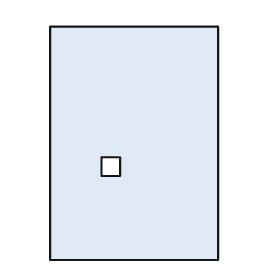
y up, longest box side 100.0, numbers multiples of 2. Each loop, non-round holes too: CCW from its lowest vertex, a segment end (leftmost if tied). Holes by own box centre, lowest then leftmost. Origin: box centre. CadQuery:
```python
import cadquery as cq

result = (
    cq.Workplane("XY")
    .moveTo(-36.0, -50.0)
    .lineTo(36.0, -50.0)
    .lineTo(36.0, 50.0)
    .lineTo(-36.0, 50.0)
    .close()
    .moveTo(-14.0, -14.0)
    .lineTo(-6.0, -14.0)
    .lineTo(-6.0, -6.0)
    .lineTo(-14.0, -6.0)
    .close()
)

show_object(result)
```